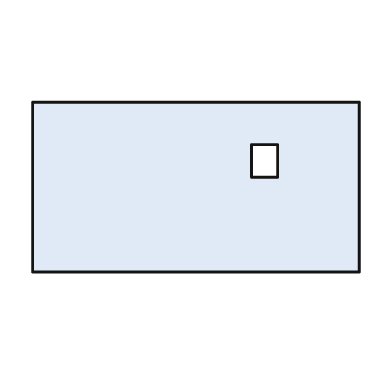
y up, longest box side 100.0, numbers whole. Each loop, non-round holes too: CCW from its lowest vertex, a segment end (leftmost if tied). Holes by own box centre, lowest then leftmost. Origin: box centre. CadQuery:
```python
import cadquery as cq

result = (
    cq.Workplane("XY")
    .moveTo(-50.0, -26.0)
    .lineTo(50.0, -26.0)
    .lineTo(50.0, 26.0)
    .lineTo(-50.0, 26.0)
    .close()
    .moveTo(17.0, 3.0)
    .lineTo(25.0, 3.0)
    .lineTo(25.0, 13.0)
    .lineTo(17.0, 13.0)
    .close()
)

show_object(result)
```